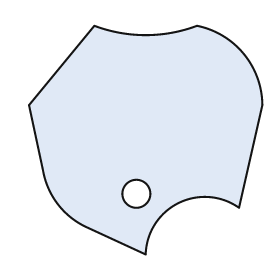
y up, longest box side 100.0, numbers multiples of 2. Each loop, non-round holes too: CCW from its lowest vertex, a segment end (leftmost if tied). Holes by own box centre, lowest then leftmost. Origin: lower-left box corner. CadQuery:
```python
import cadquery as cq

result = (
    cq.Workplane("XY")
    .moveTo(50.0, 0.0)
    .threePointArc((64.0, 22.0), (90.0, 20.0))
    .lineTo(100.0, 64.0)
    .threePointArc((92.0, 86.0), (72.0, 98.0))
    .threePointArc((50.0, 94.0), (28.0, 98.0))
    .lineTo(0.0, 64.0)
    .lineTo(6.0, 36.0)
    .threePointArc((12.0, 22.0), (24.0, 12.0))
    .close()
    .moveTo(46.0, 26.0)
    .circle(6.0)
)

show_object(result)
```